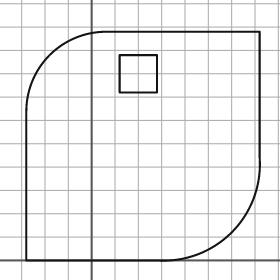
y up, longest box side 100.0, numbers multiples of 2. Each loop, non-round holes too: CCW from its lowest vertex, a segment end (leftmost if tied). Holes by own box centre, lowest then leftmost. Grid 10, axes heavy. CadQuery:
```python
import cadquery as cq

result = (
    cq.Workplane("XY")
    .moveTo(-28.0, 0.0)
    .lineTo(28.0, 0.0)
    .threePointArc((60.0, 12.0), (72.0, 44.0))
    .lineTo(72.0, 98.0)
    .lineTo(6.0, 98.0)
    .threePointArc((-18.0, 88.0), (-28.0, 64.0))
    .close()
    .moveTo(12.0, 72.0)
    .lineTo(28.0, 72.0)
    .lineTo(28.0, 88.0)
    .lineTo(12.0, 88.0)
    .close()
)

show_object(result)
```